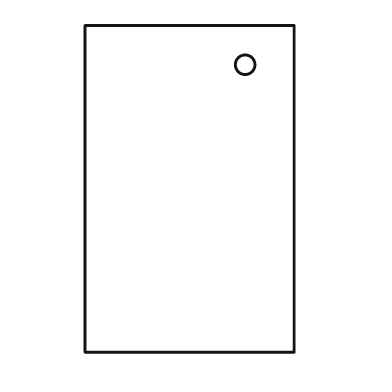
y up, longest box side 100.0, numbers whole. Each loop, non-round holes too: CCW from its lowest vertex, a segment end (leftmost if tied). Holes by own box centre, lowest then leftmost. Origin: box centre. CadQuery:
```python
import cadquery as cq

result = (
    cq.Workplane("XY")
    .moveTo(-32.0, -50.0)
    .lineTo(32.0, -50.0)
    .lineTo(32.0, 50.0)
    .lineTo(-32.0, 50.0)
    .close()
    .moveTo(17.0, 38.0)
    .circle(3.0)
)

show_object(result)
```